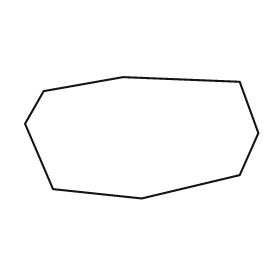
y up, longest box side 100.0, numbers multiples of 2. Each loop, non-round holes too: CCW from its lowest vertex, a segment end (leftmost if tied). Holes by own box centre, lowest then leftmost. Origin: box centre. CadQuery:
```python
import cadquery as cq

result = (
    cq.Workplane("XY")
    .moveTo(0.0, -26.0)
    .lineTo(42.0, -16.0)
    .lineTo(50.0, 2.0)
    .lineTo(42.0, 24.0)
    .lineTo(-8.0, 26.0)
    .lineTo(-42.0, 20.0)
    .lineTo(-50.0, 6.0)
    .lineTo(-38.0, -22.0)
    .close()
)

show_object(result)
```